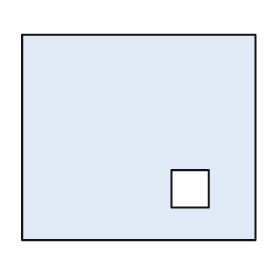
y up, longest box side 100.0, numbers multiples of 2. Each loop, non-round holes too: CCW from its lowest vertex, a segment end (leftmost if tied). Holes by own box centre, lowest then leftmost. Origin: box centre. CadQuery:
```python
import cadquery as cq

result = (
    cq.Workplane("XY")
    .moveTo(-50.0, -44.0)
    .lineTo(50.0, -44.0)
    .lineTo(50.0, 44.0)
    .lineTo(-50.0, 44.0)
    .close()
    .moveTo(14.0, -30.0)
    .lineTo(30.0, -30.0)
    .lineTo(30.0, -14.0)
    .lineTo(14.0, -14.0)
    .close()
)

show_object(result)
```